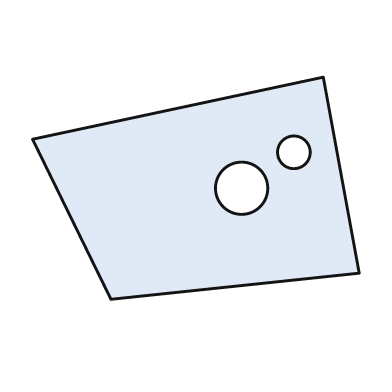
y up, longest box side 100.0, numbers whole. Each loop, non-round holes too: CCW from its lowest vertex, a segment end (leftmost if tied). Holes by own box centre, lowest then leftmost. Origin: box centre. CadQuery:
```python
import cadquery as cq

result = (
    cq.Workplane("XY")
    .moveTo(-26.0, -34.0)
    .lineTo(50.0, -26.0)
    .lineTo(39.0, 34.0)
    .lineTo(-50.0, 15.0)
    .close()
    .moveTo(14.0, 0.0)
    .circle(8.0)
    .moveTo(30.0, 11.0)
    .circle(5.0)
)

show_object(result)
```